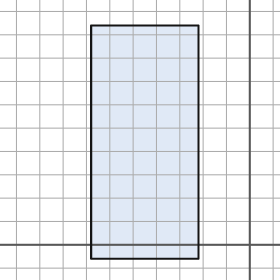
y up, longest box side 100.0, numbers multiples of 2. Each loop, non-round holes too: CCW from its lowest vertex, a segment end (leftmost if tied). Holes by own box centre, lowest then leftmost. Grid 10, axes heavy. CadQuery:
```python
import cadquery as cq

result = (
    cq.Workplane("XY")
    .moveTo(-68.0, -6.0)
    .lineTo(-22.0, -6.0)
    .lineTo(-22.0, 94.0)
    .lineTo(-68.0, 94.0)
    .close()
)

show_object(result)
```